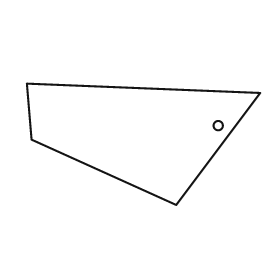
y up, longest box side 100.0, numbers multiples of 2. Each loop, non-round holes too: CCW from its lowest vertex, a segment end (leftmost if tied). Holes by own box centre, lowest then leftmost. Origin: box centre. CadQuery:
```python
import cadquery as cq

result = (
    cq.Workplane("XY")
    .moveTo(14.0, -26.0)
    .lineTo(50.0, 22.0)
    .lineTo(-50.0, 26.0)
    .lineTo(-48.0, 2.0)
    .close()
    .moveTo(32.0, 8.0)
    .circle(2.0)
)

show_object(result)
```